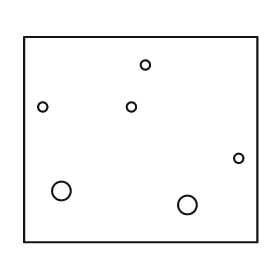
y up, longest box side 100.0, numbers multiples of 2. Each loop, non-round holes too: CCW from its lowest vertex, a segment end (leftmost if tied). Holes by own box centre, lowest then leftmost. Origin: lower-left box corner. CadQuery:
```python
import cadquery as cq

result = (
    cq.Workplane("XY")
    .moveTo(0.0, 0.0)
    .lineTo(100.0, 0.0)
    .lineTo(100.0, 88.0)
    .lineTo(0.0, 88.0)
    .close()
    .moveTo(70.0, 16.0)
    .circle(4.0)
    .moveTo(16.0, 22.0)
    .circle(4.0)
    .moveTo(92.0, 36.0)
    .circle(2.0)
    .moveTo(8.0, 58.0)
    .circle(2.0)
    .moveTo(46.0, 58.0)
    .circle(2.0)
    .moveTo(52.0, 76.0)
    .circle(2.0)
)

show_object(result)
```